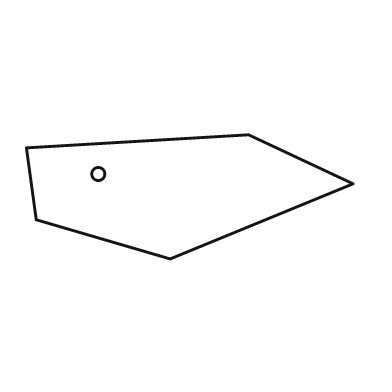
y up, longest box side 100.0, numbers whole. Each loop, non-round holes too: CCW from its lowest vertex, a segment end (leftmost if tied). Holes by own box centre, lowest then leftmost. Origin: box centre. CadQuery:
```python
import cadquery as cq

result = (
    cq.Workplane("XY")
    .moveTo(-6.0, -19.0)
    .lineTo(50.0, 4.0)
    .lineTo(18.0, 19.0)
    .lineTo(-50.0, 15.0)
    .lineTo(-47.0, -7.0)
    .close()
    .moveTo(-28.0, 7.0)
    .circle(2.0)
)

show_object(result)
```